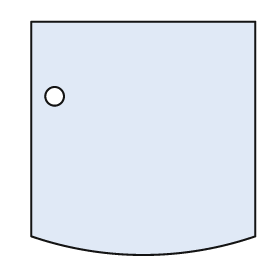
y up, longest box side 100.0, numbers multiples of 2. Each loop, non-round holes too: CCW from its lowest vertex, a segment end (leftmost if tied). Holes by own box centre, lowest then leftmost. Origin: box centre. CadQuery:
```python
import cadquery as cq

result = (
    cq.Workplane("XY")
    .moveTo(-48.0, -42.0)
    .threePointArc((0.0, -50.0), (48.0, -42.0))
    .lineTo(48.0, 50.0)
    .lineTo(-48.0, 50.0)
    .close()
    .moveTo(-38.0, 18.0)
    .circle(4.0)
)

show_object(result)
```